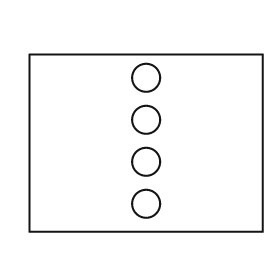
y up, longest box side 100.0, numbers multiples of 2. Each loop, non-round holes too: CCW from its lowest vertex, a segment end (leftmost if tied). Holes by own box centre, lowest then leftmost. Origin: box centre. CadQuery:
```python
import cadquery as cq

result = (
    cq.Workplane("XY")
    .moveTo(-50.0, -38.0)
    .lineTo(50.0, -38.0)
    .lineTo(50.0, 38.0)
    .lineTo(-50.0, 38.0)
    .close()
    .moveTo(0.0, -26.0)
    .circle(6.0)
    .moveTo(0.0, -8.0)
    .circle(6.0)
    .moveTo(0.0, 10.0)
    .circle(6.0)
    .moveTo(0.0, 28.0)
    .circle(6.0)
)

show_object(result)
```